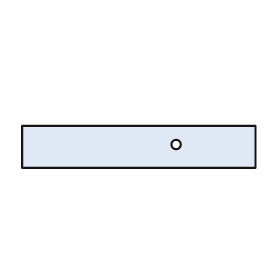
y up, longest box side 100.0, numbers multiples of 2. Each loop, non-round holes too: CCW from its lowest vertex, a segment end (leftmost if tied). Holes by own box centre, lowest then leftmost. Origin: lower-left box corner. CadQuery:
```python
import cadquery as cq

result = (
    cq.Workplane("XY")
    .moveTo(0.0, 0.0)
    .lineTo(100.0, 0.0)
    .lineTo(100.0, 18.0)
    .lineTo(0.0, 18.0)
    .close()
    .moveTo(66.0, 10.0)
    .circle(2.0)
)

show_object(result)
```